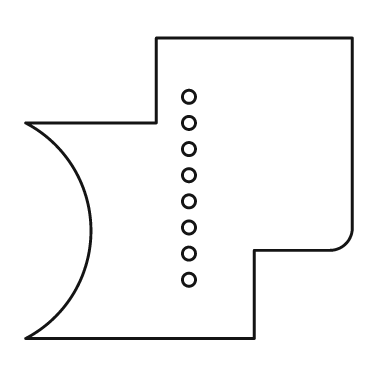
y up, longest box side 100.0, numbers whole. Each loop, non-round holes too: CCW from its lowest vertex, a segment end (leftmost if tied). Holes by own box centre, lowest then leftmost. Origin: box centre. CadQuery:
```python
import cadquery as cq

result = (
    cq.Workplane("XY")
    .moveTo(-50.0, -46.0)
    .lineTo(20.0, -46.0)
    .lineTo(20.0, -19.0)
    .lineTo(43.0, -19.0)
    .threePointArc((48.0, -17.0), (50.0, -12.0))
    .lineTo(50.0, 46.0)
    .lineTo(-10.0, 46.0)
    .lineTo(-10.0, 20.0)
    .lineTo(-50.0, 20.0)
    .threePointArc((-30.0, -13.0), (-50.0, -46.0))
    .close()
    .moveTo(0.0, -28.0)
    .circle(2.0)
    .moveTo(0.0, -20.0)
    .circle(2.0)
    .moveTo(0.0, -12.0)
    .circle(2.0)
    .moveTo(0.0, -4.0)
    .circle(2.0)
    .moveTo(0.0, 4.0)
    .circle(2.0)
    .moveTo(0.0, 12.0)
    .circle(2.0)
    .moveTo(0.0, 20.0)
    .circle(2.0)
    .moveTo(0.0, 28.0)
    .circle(2.0)
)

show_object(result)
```